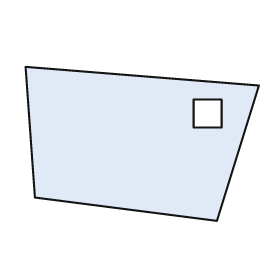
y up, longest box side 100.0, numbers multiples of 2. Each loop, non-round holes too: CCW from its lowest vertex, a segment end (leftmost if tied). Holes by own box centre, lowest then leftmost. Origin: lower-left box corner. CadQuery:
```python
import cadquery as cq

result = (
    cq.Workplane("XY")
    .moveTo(82.0, 0.0)
    .lineTo(100.0, 58.0)
    .lineTo(0.0, 66.0)
    .lineTo(4.0, 10.0)
    .close()
    .moveTo(72.0, 40.0)
    .lineTo(84.0, 40.0)
    .lineTo(84.0, 52.0)
    .lineTo(72.0, 52.0)
    .close()
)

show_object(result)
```